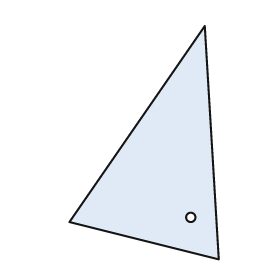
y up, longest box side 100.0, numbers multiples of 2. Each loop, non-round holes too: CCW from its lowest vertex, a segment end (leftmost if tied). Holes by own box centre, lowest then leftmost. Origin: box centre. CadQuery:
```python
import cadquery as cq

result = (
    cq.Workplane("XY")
    .moveTo(32.0, -50.0)
    .lineTo(26.0, 50.0)
    .lineTo(-32.0, -34.0)
    .close()
    .moveTo(20.0, -32.0)
    .circle(2.0)
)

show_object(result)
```